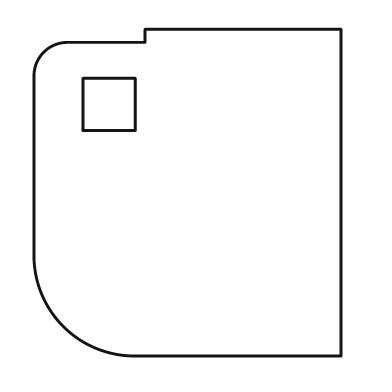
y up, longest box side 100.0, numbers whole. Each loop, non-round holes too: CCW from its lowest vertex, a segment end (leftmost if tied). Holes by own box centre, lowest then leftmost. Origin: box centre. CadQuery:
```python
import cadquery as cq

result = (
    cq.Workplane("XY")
    .moveTo(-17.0, -50.0)
    .lineTo(47.0, -50.0)
    .lineTo(47.0, 50.0)
    .lineTo(-13.0, 50.0)
    .lineTo(-13.0, 46.0)
    .lineTo(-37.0, 46.0)
    .threePointArc((-44.0, 43.0), (-47.0, 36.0))
    .lineTo(-47.0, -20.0)
    .threePointArc((-38.0, -41.0), (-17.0, -50.0))
    .close()
    .moveTo(-32.0, 19.0)
    .lineTo(-16.0, 19.0)
    .lineTo(-16.0, 35.0)
    .lineTo(-32.0, 35.0)
    .close()
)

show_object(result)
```